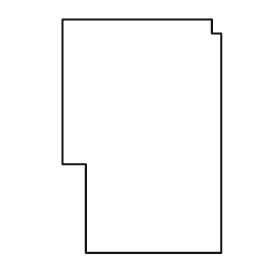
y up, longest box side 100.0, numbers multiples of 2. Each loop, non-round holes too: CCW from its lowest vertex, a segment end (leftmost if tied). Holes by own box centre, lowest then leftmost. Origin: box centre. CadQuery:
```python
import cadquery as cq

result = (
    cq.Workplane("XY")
    .moveTo(-24.0, -50.0)
    .lineTo(34.0, -50.0)
    .lineTo(34.0, 44.0)
    .lineTo(30.0, 44.0)
    .lineTo(30.0, 50.0)
    .lineTo(-34.0, 50.0)
    .lineTo(-34.0, -12.0)
    .lineTo(-24.0, -12.0)
    .close()
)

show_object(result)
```